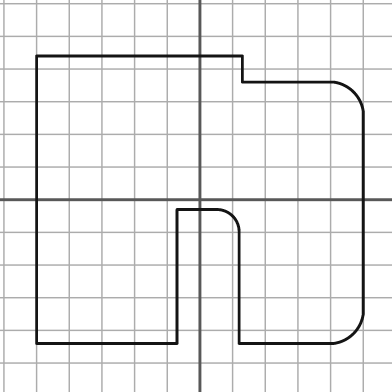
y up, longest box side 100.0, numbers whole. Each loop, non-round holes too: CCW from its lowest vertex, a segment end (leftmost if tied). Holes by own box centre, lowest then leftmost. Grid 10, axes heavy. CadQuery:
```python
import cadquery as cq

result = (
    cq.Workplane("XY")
    .moveTo(-50.0, -44.0)
    .lineTo(-7.0, -44.0)
    .lineTo(-7.0, -3.0)
    .lineTo(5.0, -3.0)
    .threePointArc((10.0, -5.0), (12.0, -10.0))
    .lineTo(12.0, -44.0)
    .lineTo(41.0, -44.0)
    .threePointArc((47.0, -41.0), (50.0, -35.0))
    .lineTo(50.0, 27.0)
    .threePointArc((47.0, 33.0), (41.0, 36.0))
    .lineTo(13.0, 36.0)
    .lineTo(13.0, 44.0)
    .lineTo(-50.0, 44.0)
    .close()
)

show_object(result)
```